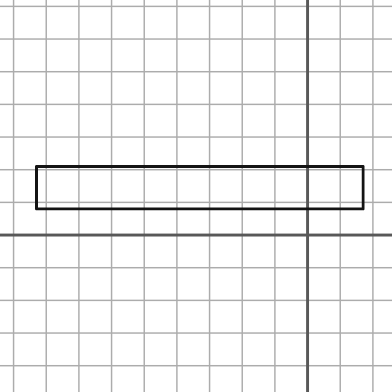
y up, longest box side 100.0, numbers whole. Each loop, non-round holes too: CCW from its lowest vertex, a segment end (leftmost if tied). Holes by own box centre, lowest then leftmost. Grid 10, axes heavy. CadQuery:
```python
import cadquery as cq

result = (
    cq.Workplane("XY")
    .moveTo(-83.0, 8.0)
    .lineTo(17.0, 8.0)
    .lineTo(17.0, 21.0)
    .lineTo(-83.0, 21.0)
    .close()
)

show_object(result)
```